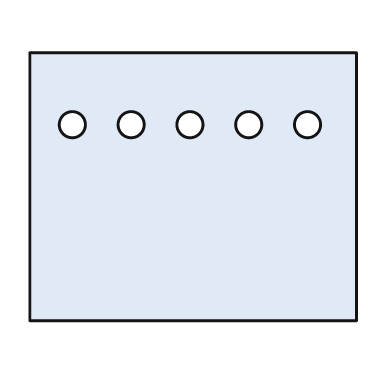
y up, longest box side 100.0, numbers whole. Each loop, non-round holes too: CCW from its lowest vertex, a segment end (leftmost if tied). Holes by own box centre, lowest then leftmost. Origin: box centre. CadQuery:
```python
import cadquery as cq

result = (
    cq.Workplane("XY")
    .moveTo(-50.0, -41.0)
    .lineTo(50.0, -41.0)
    .lineTo(50.0, 41.0)
    .lineTo(-50.0, 41.0)
    .close()
    .moveTo(-37.0, 19.0)
    .circle(4.0)
    .moveTo(-19.0, 19.0)
    .circle(4.0)
    .moveTo(-1.0, 19.0)
    .circle(4.0)
    .moveTo(17.0, 19.0)
    .circle(4.0)
    .moveTo(35.0, 19.0)
    .circle(4.0)
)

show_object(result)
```